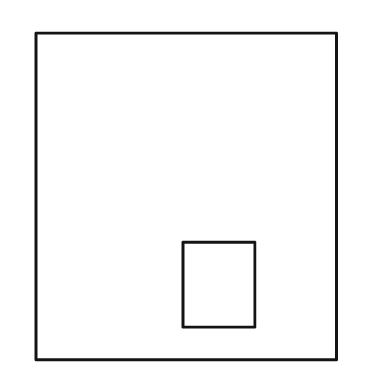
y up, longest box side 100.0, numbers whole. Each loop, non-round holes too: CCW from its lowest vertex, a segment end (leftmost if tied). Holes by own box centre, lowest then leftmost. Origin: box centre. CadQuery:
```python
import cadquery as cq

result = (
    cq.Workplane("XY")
    .moveTo(-46.0, -50.0)
    .lineTo(46.0, -50.0)
    .lineTo(46.0, 50.0)
    .lineTo(-46.0, 50.0)
    .close()
    .moveTo(-1.0, -40.0)
    .lineTo(21.0, -40.0)
    .lineTo(21.0, -14.0)
    .lineTo(-1.0, -14.0)
    .close()
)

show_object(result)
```